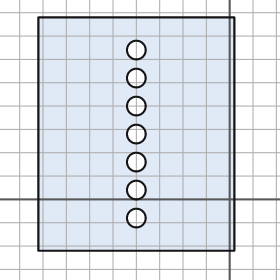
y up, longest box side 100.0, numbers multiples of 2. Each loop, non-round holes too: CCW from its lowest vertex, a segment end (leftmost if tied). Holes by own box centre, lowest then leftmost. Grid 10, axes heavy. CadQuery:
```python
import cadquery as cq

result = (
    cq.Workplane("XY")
    .moveTo(-82.0, -22.0)
    .lineTo(2.0, -22.0)
    .lineTo(2.0, 78.0)
    .lineTo(-82.0, 78.0)
    .close()
    .moveTo(-40.0, -8.0)
    .circle(4.0)
    .moveTo(-40.0, 4.0)
    .circle(4.0)
    .moveTo(-40.0, 16.0)
    .circle(4.0)
    .moveTo(-40.0, 28.0)
    .circle(4.0)
    .moveTo(-40.0, 40.0)
    .circle(4.0)
    .moveTo(-40.0, 52.0)
    .circle(4.0)
    .moveTo(-40.0, 64.0)
    .circle(4.0)
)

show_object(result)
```